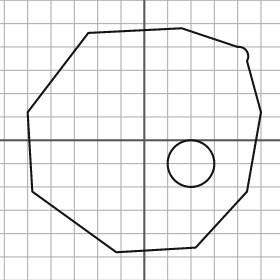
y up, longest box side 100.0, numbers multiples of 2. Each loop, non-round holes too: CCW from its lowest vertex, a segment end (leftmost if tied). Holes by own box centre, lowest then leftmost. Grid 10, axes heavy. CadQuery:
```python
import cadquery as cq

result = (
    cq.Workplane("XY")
    .moveTo(-12.0, -48.0)
    .lineTo(22.0, -46.0)
    .lineTo(44.0, -22.0)
    .lineTo(50.0, 12.0)
    .lineTo(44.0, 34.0)
    .threePointArc((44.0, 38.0), (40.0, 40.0))
    .lineTo(16.0, 48.0)
    .lineTo(-24.0, 46.0)
    .lineTo(-50.0, 12.0)
    .lineTo(-48.0, -22.0)
    .close()
    .moveTo(20.0, -10.0)
    .circle(10.0)
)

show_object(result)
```